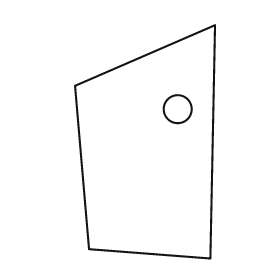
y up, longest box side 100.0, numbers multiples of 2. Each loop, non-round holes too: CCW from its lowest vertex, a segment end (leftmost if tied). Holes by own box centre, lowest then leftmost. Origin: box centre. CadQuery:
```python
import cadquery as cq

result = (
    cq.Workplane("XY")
    .moveTo(28.0, -50.0)
    .lineTo(30.0, 50.0)
    .lineTo(-30.0, 24.0)
    .lineTo(-24.0, -46.0)
    .close()
    .moveTo(14.0, 14.0)
    .circle(6.0)
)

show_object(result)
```